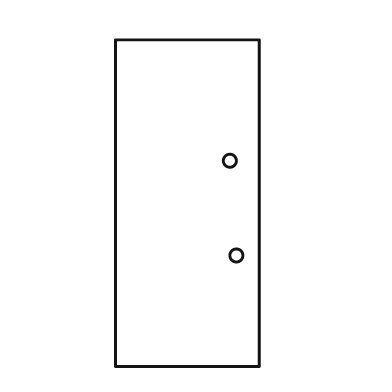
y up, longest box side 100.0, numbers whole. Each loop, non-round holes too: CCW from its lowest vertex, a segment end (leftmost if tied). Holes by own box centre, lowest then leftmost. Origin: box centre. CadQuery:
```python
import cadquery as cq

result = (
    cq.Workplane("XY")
    .moveTo(-22.0, -50.0)
    .lineTo(22.0, -50.0)
    .lineTo(22.0, 50.0)
    .lineTo(-22.0, 50.0)
    .close()
    .moveTo(15.0, -16.0)
    .circle(2.0)
    .moveTo(13.0, 13.0)
    .circle(2.0)
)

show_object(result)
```